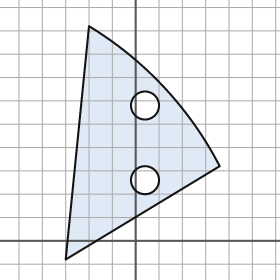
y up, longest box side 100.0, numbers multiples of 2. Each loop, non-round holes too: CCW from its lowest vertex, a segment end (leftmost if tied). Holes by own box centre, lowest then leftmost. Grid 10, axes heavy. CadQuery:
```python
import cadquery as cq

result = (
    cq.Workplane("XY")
    .moveTo(-30.0, -8.0)
    .lineTo(36.0, 32.0)
    .threePointArc((12.0, 66.0), (-20.0, 92.0))
    .close()
    .moveTo(4.0, 26.0)
    .circle(6.0)
    .moveTo(4.0, 58.0)
    .circle(6.0)
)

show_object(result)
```